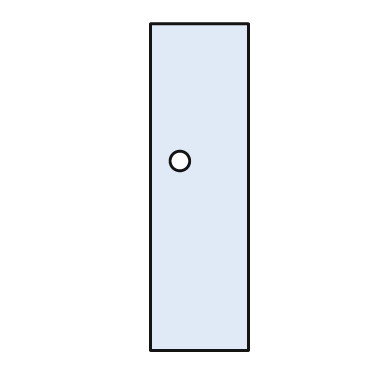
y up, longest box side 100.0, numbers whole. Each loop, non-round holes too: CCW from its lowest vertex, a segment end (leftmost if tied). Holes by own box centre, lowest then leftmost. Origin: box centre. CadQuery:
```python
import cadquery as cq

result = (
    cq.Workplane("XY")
    .moveTo(-15.0, -50.0)
    .lineTo(15.0, -50.0)
    .lineTo(15.0, 50.0)
    .lineTo(-15.0, 50.0)
    .close()
    .moveTo(-6.0, 8.0)
    .circle(3.0)
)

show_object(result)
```